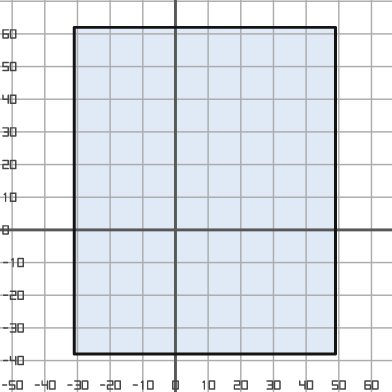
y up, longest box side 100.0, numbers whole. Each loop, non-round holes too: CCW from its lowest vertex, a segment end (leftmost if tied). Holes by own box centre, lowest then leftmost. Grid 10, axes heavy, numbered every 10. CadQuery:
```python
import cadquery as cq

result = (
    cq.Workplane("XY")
    .moveTo(-31.0, -38.0)
    .lineTo(49.0, -38.0)
    .lineTo(49.0, 62.0)
    .lineTo(-31.0, 62.0)
    .close()
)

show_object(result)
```